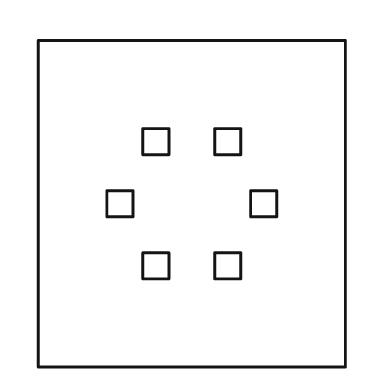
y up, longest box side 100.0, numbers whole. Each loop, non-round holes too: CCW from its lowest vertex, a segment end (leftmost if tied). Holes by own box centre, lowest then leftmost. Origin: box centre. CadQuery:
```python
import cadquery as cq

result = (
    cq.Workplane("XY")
    .moveTo(-47.0, -50.0)
    .lineTo(47.0, -50.0)
    .lineTo(47.0, 50.0)
    .lineTo(-47.0, 50.0)
    .close()
    .moveTo(-15.0, -23.0)
    .lineTo(-7.0, -23.0)
    .lineTo(-7.0, -15.0)
    .lineTo(-15.0, -15.0)
    .close()
    .moveTo(7.0, -23.0)
    .lineTo(15.0, -23.0)
    .lineTo(15.0, -15.0)
    .lineTo(7.0, -15.0)
    .close()
    .moveTo(-26.0, -4.0)
    .lineTo(-18.0, -4.0)
    .lineTo(-18.0, 4.0)
    .lineTo(-26.0, 4.0)
    .close()
    .moveTo(18.0, -4.0)
    .lineTo(26.0, -4.0)
    .lineTo(26.0, 4.0)
    .lineTo(18.0, 4.0)
    .close()
    .moveTo(-15.0, 15.0)
    .lineTo(-7.0, 15.0)
    .lineTo(-7.0, 23.0)
    .lineTo(-15.0, 23.0)
    .close()
    .moveTo(7.0, 15.0)
    .lineTo(15.0, 15.0)
    .lineTo(15.0, 23.0)
    .lineTo(7.0, 23.0)
    .close()
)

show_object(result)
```